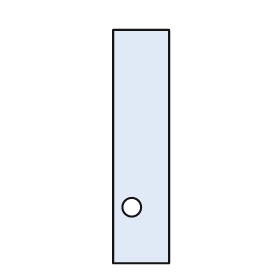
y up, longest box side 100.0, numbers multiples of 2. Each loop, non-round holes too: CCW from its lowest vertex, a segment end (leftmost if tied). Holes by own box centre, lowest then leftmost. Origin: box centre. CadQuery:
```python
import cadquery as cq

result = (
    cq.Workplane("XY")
    .moveTo(-12.0, -50.0)
    .lineTo(12.0, -50.0)
    .lineTo(12.0, 50.0)
    .lineTo(-12.0, 50.0)
    .close()
    .moveTo(-4.0, -26.0)
    .circle(4.0)
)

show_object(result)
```